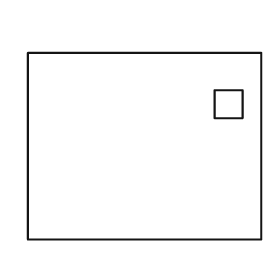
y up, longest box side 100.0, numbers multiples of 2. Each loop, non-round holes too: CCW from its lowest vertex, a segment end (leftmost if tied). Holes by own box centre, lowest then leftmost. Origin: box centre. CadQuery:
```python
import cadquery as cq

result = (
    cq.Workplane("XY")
    .moveTo(-50.0, -40.0)
    .lineTo(50.0, -40.0)
    .lineTo(50.0, 40.0)
    .lineTo(-50.0, 40.0)
    .close()
    .moveTo(30.0, 12.0)
    .lineTo(42.0, 12.0)
    .lineTo(42.0, 24.0)
    .lineTo(30.0, 24.0)
    .close()
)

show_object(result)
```